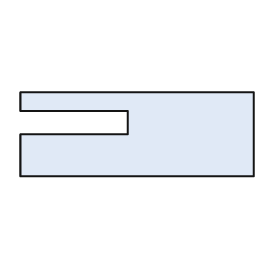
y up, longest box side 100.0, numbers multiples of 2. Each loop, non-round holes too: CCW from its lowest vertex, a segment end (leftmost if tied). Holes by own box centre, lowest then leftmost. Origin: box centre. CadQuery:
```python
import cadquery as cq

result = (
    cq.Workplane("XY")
    .moveTo(-50.0, -18.0)
    .lineTo(50.0, -18.0)
    .lineTo(50.0, 18.0)
    .lineTo(-50.0, 18.0)
    .lineTo(-50.0, 10.0)
    .lineTo(-4.0, 10.0)
    .lineTo(-4.0, 0.0)
    .lineTo(-50.0, 0.0)
    .close()
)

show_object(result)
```